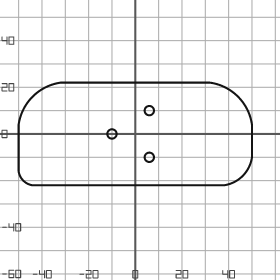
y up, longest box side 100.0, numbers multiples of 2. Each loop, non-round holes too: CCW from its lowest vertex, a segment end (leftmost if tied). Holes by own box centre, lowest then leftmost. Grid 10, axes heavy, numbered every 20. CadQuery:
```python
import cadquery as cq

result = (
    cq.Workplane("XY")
    .moveTo(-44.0, -22.0)
    .lineTo(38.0, -22.0)
    .threePointArc((46.0, -18.0), (50.0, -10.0))
    .lineTo(50.0, 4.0)
    .threePointArc((44.0, 16.0), (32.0, 22.0))
    .lineTo(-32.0, 22.0)
    .threePointArc((-44.0, 16.0), (-50.0, 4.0))
    .lineTo(-50.0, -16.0)
    .threePointArc((-48.0, -20.0), (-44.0, -22.0))
    .close()
    .moveTo(6.0, -10.0)
    .circle(2.0)
    .moveTo(-10.0, 0.0)
    .circle(2.0)
    .moveTo(6.0, 10.0)
    .circle(2.0)
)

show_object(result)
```